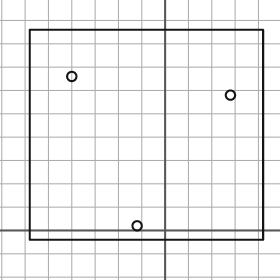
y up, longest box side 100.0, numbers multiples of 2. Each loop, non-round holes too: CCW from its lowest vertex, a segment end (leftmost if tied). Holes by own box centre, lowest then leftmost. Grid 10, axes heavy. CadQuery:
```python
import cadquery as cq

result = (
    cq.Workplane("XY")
    .moveTo(-58.0, -4.0)
    .lineTo(42.0, -4.0)
    .lineTo(42.0, 86.0)
    .lineTo(-58.0, 86.0)
    .close()
    .moveTo(-12.0, 2.0)
    .circle(2.0)
    .moveTo(28.0, 58.0)
    .circle(2.0)
    .moveTo(-40.0, 66.0)
    .circle(2.0)
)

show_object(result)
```